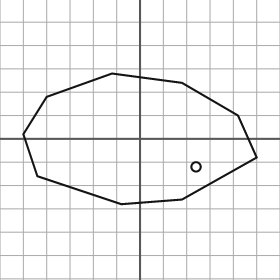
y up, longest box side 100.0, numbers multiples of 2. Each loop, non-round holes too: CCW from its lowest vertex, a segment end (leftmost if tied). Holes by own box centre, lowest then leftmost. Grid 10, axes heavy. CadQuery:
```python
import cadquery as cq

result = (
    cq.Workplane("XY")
    .moveTo(-8.0, -28.0)
    .lineTo(18.0, -26.0)
    .lineTo(50.0, -8.0)
    .lineTo(42.0, 10.0)
    .lineTo(18.0, 24.0)
    .lineTo(-12.0, 28.0)
    .lineTo(-40.0, 18.0)
    .lineTo(-50.0, 2.0)
    .lineTo(-44.0, -16.0)
    .close()
    .moveTo(24.0, -12.0)
    .circle(2.0)
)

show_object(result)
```